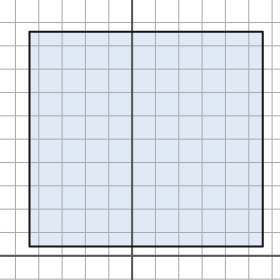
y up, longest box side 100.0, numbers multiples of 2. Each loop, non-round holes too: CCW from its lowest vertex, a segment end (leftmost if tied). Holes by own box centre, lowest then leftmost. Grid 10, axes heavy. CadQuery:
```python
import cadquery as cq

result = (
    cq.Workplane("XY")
    .moveTo(-44.0, 4.0)
    .lineTo(56.0, 4.0)
    .lineTo(56.0, 96.0)
    .lineTo(-44.0, 96.0)
    .close()
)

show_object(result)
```